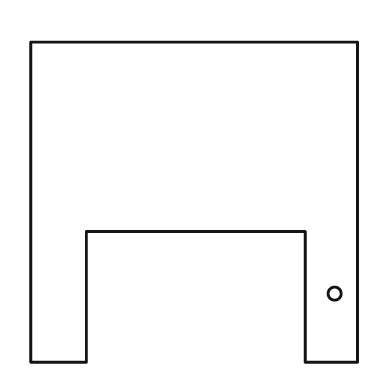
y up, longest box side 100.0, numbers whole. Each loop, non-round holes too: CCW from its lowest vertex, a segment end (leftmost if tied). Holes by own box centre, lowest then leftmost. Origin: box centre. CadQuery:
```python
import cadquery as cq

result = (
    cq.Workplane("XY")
    .moveTo(-50.0, -49.0)
    .lineTo(-33.0, -49.0)
    .lineTo(-33.0, -9.0)
    .lineTo(34.0, -9.0)
    .lineTo(34.0, -49.0)
    .lineTo(50.0, -49.0)
    .lineTo(50.0, 49.0)
    .lineTo(-50.0, 49.0)
    .close()
    .moveTo(43.0, -28.0)
    .circle(2.0)
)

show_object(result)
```